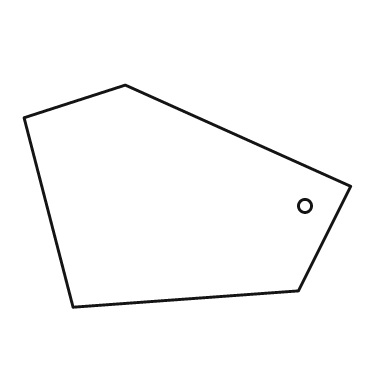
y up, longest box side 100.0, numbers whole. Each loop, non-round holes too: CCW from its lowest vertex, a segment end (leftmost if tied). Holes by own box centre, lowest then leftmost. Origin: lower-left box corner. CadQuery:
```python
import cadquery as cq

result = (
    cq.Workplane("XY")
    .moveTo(15.0, 0.0)
    .lineTo(84.0, 5.0)
    .lineTo(100.0, 37.0)
    .lineTo(31.0, 68.0)
    .lineTo(0.0, 58.0)
    .close()
    .moveTo(86.0, 31.0)
    .circle(2.0)
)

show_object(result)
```